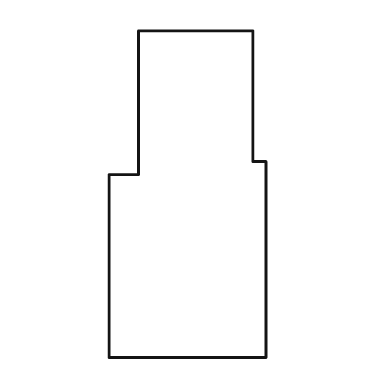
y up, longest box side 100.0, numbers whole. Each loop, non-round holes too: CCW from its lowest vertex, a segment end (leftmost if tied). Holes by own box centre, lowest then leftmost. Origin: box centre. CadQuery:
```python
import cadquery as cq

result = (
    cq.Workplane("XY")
    .moveTo(-24.0, -50.0)
    .lineTo(24.0, -50.0)
    .lineTo(24.0, 10.0)
    .lineTo(20.0, 10.0)
    .lineTo(20.0, 50.0)
    .lineTo(-15.0, 50.0)
    .lineTo(-15.0, 6.0)
    .lineTo(-24.0, 6.0)
    .close()
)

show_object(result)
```